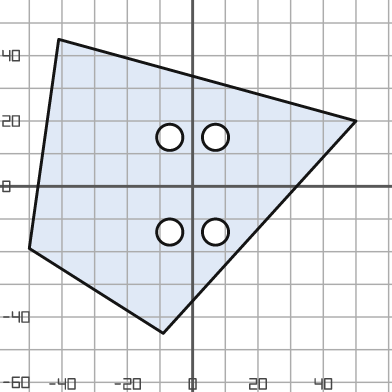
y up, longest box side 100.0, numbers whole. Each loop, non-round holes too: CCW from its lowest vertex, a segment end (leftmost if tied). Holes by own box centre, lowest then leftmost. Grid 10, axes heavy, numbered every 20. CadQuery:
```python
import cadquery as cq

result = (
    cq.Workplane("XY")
    .moveTo(-9.0, -45.0)
    .lineTo(50.0, 20.0)
    .lineTo(-41.0, 45.0)
    .lineTo(-50.0, -19.0)
    .close()
    .moveTo(-7.0, -14.0)
    .circle(4.0)
    .moveTo(7.0, -14.0)
    .circle(4.0)
    .moveTo(-7.0, 15.0)
    .circle(4.0)
    .moveTo(7.0, 15.0)
    .circle(4.0)
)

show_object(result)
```